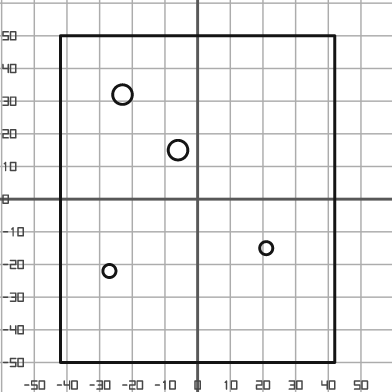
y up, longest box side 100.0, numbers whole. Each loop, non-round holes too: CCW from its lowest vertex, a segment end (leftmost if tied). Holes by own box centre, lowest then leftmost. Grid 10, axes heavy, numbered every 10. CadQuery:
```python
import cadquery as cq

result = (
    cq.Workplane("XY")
    .moveTo(-42.0, -50.0)
    .lineTo(42.0, -50.0)
    .lineTo(42.0, 50.0)
    .lineTo(-42.0, 50.0)
    .close()
    .moveTo(-27.0, -22.0)
    .circle(2.0)
    .moveTo(21.0, -15.0)
    .circle(2.0)
    .moveTo(-6.0, 15.0)
    .circle(3.0)
    .moveTo(-23.0, 32.0)
    .circle(3.0)
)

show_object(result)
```